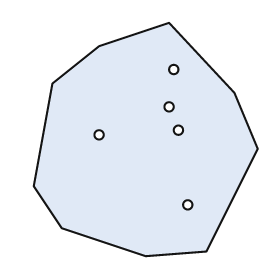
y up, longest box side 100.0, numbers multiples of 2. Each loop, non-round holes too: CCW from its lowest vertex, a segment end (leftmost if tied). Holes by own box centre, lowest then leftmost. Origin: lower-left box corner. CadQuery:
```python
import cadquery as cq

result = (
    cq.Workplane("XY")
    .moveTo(48.0, 0.0)
    .lineTo(74.0, 2.0)
    .lineTo(96.0, 46.0)
    .lineTo(86.0, 70.0)
    .lineTo(58.0, 100.0)
    .lineTo(28.0, 90.0)
    .lineTo(8.0, 74.0)
    .lineTo(0.0, 30.0)
    .lineTo(12.0, 12.0)
    .close()
    .moveTo(66.0, 22.0)
    .circle(2.0)
    .moveTo(28.0, 52.0)
    .circle(2.0)
    .moveTo(62.0, 54.0)
    .circle(2.0)
    .moveTo(58.0, 64.0)
    .circle(2.0)
    .moveTo(60.0, 80.0)
    .circle(2.0)
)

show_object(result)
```